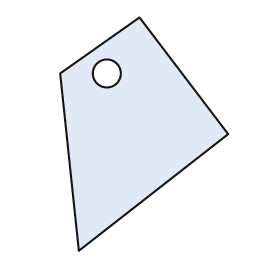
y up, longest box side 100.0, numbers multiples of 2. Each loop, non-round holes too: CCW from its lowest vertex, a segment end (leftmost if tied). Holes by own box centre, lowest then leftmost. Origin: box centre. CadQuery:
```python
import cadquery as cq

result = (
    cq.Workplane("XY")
    .moveTo(-28.0, -50.0)
    .lineTo(36.0, 0.0)
    .lineTo(-2.0, 50.0)
    .lineTo(-36.0, 26.0)
    .close()
    .moveTo(-16.0, 26.0)
    .circle(6.0)
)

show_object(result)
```